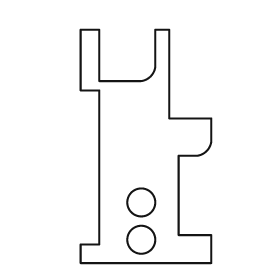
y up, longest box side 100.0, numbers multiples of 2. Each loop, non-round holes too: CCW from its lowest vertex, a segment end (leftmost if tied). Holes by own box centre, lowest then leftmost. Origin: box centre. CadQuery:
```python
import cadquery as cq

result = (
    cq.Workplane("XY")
    .moveTo(-28.0, -50.0)
    .lineTo(28.0, -50.0)
    .lineTo(28.0, -38.0)
    .lineTo(14.0, -38.0)
    .lineTo(14.0, -4.0)
    .lineTo(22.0, -4.0)
    .threePointArc((26.0, -2.0), (28.0, 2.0))
    .lineTo(28.0, 12.0)
    .lineTo(10.0, 12.0)
    .lineTo(10.0, 50.0)
    .lineTo(4.0, 50.0)
    .lineTo(4.0, 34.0)
    .threePointArc((2.0, 30.0), (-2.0, 28.0))
    .lineTo(-20.0, 28.0)
    .lineTo(-20.0, 50.0)
    .lineTo(-28.0, 50.0)
    .lineTo(-28.0, 24.0)
    .lineTo(-20.0, 24.0)
    .lineTo(-20.0, -42.0)
    .lineTo(-28.0, -42.0)
    .close()
    .moveTo(-2.0, -40.0)
    .circle(6.0)
    .moveTo(-2.0, -24.0)
    .circle(6.0)
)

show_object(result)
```